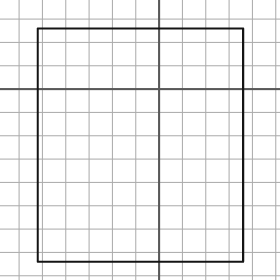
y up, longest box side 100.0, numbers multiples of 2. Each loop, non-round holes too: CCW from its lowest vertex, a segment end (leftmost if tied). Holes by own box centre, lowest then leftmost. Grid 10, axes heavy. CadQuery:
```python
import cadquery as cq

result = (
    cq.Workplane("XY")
    .moveTo(-52.0, -74.0)
    .lineTo(36.0, -74.0)
    .lineTo(36.0, 26.0)
    .lineTo(-52.0, 26.0)
    .close()
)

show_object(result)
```